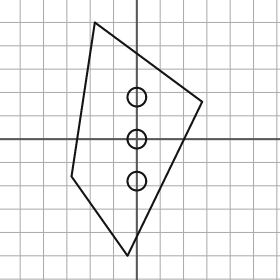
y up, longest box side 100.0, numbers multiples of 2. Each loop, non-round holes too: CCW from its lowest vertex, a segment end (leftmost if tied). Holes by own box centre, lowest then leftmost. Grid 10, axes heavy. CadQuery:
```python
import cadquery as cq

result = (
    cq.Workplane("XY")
    .moveTo(-4.0, -50.0)
    .lineTo(28.0, 16.0)
    .lineTo(-18.0, 50.0)
    .lineTo(-28.0, -16.0)
    .close()
    .moveTo(0.0, -18.0)
    .circle(4.0)
    .moveTo(0.0, 0.0)
    .circle(4.0)
    .moveTo(0.0, 18.0)
    .circle(4.0)
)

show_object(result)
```